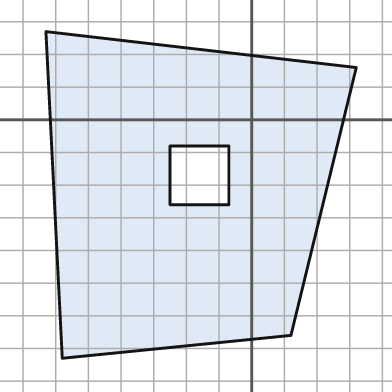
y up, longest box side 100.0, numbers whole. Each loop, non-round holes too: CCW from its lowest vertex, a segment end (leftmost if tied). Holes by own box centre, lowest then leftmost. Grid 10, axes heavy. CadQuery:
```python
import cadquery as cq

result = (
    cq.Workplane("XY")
    .moveTo(-58.0, -73.0)
    .lineTo(12.0, -66.0)
    .lineTo(32.0, 16.0)
    .lineTo(-63.0, 27.0)
    .close()
    .moveTo(-25.0, -26.0)
    .lineTo(-7.0, -26.0)
    .lineTo(-7.0, -8.0)
    .lineTo(-25.0, -8.0)
    .close()
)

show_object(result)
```